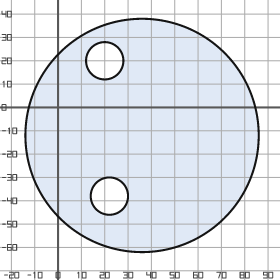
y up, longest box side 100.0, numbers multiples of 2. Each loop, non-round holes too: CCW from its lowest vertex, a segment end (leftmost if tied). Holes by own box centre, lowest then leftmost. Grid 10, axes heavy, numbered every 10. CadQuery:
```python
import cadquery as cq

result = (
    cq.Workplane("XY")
    .moveTo(36.0, -12.0)
    .circle(50.0)
    .moveTo(22.0, -38.0)
    .circle(8.0)
    .moveTo(20.0, 20.0)
    .circle(8.0)
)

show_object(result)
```